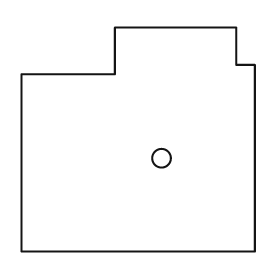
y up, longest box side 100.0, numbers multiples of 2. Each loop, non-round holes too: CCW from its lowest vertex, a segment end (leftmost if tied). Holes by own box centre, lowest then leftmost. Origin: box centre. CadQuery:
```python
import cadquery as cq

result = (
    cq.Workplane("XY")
    .moveTo(-50.0, -48.0)
    .lineTo(50.0, -48.0)
    .lineTo(50.0, 32.0)
    .lineTo(42.0, 32.0)
    .lineTo(42.0, 48.0)
    .lineTo(-10.0, 48.0)
    .lineTo(-10.0, 28.0)
    .lineTo(-50.0, 28.0)
    .close()
    .moveTo(10.0, -8.0)
    .circle(4.0)
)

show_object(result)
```